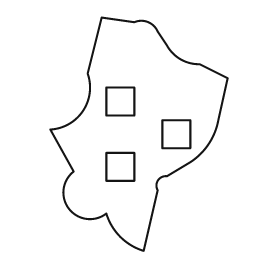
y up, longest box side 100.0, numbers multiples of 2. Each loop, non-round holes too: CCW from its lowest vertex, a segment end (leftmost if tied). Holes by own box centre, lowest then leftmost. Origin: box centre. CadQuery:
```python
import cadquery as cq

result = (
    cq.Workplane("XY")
    .moveTo(2.0, -50.0)
    .lineTo(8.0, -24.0)
    .threePointArc((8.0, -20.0), (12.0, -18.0))
    .lineTo(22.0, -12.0)
    .threePointArc((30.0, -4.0), (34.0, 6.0))
    .lineTo(38.0, 24.0)
    .lineTo(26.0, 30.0)
    .threePointArc((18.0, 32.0), (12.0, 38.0))
    .lineTo(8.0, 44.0)
    .threePointArc((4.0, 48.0), (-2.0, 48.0))
    .lineTo(-16.0, 50.0)
    .lineTo(-22.0, 26.0)
    .threePointArc((-24.0, 10.0), (-38.0, 2.0))
    .lineTo(-28.0, -16.0)
    .threePointArc((-30.0, -32.0), (-14.0, -34.0))
    .threePointArc((-8.0, -44.0), (2.0, -50.0))
    .close()
    .moveTo(-14.0, -20.0)
    .lineTo(-2.0, -20.0)
    .lineTo(-2.0, -8.0)
    .lineTo(-14.0, -8.0)
    .close()
    .moveTo(10.0, -6.0)
    .lineTo(22.0, -6.0)
    .lineTo(22.0, 6.0)
    .lineTo(10.0, 6.0)
    .close()
    .moveTo(-14.0, 8.0)
    .lineTo(-2.0, 8.0)
    .lineTo(-2.0, 20.0)
    .lineTo(-14.0, 20.0)
    .close()
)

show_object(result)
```